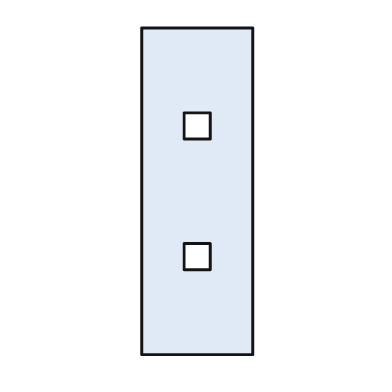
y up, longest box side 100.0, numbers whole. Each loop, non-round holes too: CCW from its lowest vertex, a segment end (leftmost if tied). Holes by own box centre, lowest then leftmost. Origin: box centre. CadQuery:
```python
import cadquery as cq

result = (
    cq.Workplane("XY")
    .moveTo(-17.0, -50.0)
    .lineTo(17.0, -50.0)
    .lineTo(17.0, 50.0)
    .lineTo(-17.0, 50.0)
    .close()
    .moveTo(-4.0, -24.0)
    .lineTo(4.0, -24.0)
    .lineTo(4.0, -16.0)
    .lineTo(-4.0, -16.0)
    .close()
    .moveTo(-4.0, 16.0)
    .lineTo(4.0, 16.0)
    .lineTo(4.0, 24.0)
    .lineTo(-4.0, 24.0)
    .close()
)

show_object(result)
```